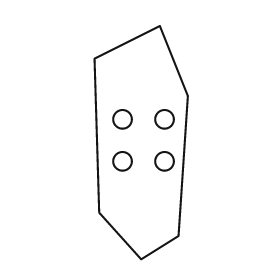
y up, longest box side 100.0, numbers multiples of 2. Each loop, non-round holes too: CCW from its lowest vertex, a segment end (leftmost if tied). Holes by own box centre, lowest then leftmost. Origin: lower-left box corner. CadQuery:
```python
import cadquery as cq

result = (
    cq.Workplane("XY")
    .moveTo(20.0, 0.0)
    .lineTo(36.0, 10.0)
    .lineTo(40.0, 70.0)
    .lineTo(28.0, 100.0)
    .lineTo(0.0, 86.0)
    .lineTo(2.0, 20.0)
    .close()
    .moveTo(12.0, 42.0)
    .circle(4.0)
    .moveTo(30.0, 42.0)
    .circle(4.0)
    .moveTo(12.0, 60.0)
    .circle(4.0)
    .moveTo(30.0, 60.0)
    .circle(4.0)
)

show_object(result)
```